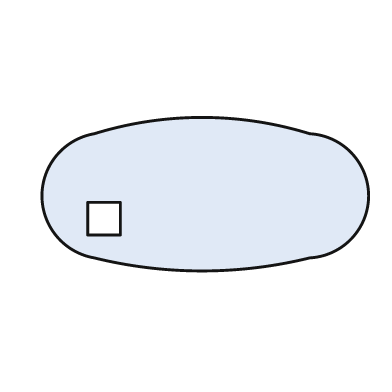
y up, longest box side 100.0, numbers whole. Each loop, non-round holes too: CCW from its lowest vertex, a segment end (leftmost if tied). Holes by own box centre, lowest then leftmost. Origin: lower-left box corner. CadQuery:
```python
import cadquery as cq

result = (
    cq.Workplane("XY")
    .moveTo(16.0, 4.0)
    .threePointArc((49.0, 0.0), (82.0, 4.0))
    .threePointArc((100.0, 23.0), (82.0, 42.0))
    .threePointArc((49.0, 47.0), (16.0, 42.0))
    .threePointArc((0.0, 23.0), (16.0, 4.0))
    .close()
    .moveTo(14.0, 11.0)
    .lineTo(24.0, 11.0)
    .lineTo(24.0, 21.0)
    .lineTo(14.0, 21.0)
    .close()
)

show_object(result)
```